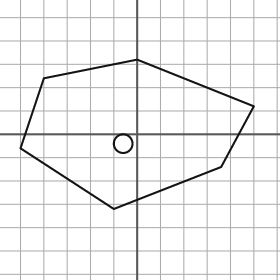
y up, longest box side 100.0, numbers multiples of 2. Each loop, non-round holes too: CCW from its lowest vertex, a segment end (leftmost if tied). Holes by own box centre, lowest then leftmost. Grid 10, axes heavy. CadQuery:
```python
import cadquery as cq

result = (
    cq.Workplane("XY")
    .moveTo(-10.0, -32.0)
    .lineTo(36.0, -14.0)
    .lineTo(50.0, 12.0)
    .lineTo(0.0, 32.0)
    .lineTo(-40.0, 24.0)
    .lineTo(-50.0, -6.0)
    .close()
    .moveTo(-6.0, -4.0)
    .circle(4.0)
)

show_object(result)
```